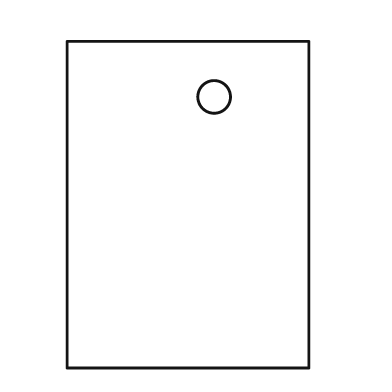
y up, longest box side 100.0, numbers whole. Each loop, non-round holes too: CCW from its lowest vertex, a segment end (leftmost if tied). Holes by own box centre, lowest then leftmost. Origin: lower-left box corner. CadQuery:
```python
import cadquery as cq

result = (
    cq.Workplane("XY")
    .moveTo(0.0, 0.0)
    .lineTo(74.0, 0.0)
    .lineTo(74.0, 100.0)
    .lineTo(0.0, 100.0)
    .close()
    .moveTo(45.0, 83.0)
    .circle(5.0)
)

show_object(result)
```